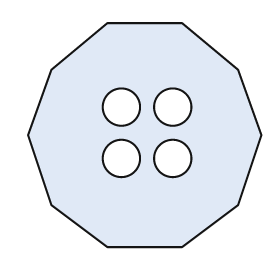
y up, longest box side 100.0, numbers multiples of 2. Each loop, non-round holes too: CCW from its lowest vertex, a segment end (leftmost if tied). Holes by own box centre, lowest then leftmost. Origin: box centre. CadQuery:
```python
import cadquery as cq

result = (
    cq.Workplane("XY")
    .moveTo(-16.0, -48.0)
    .lineTo(16.0, -48.0)
    .lineTo(40.0, -30.0)
    .lineTo(50.0, 0.0)
    .lineTo(40.0, 28.0)
    .lineTo(16.0, 48.0)
    .lineTo(-16.0, 48.0)
    .lineTo(-40.0, 28.0)
    .lineTo(-50.0, 0.0)
    .lineTo(-40.0, -30.0)
    .close()
    .moveTo(-10.0, -10.0)
    .circle(8.0)
    .moveTo(12.0, -10.0)
    .circle(8.0)
    .moveTo(-10.0, 12.0)
    .circle(8.0)
    .moveTo(12.0, 12.0)
    .circle(8.0)
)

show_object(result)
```